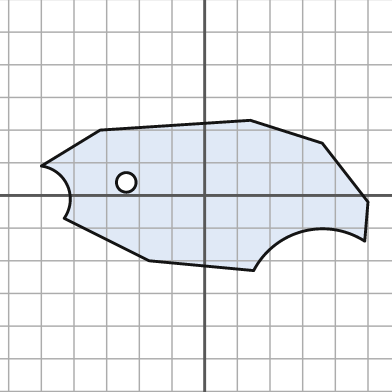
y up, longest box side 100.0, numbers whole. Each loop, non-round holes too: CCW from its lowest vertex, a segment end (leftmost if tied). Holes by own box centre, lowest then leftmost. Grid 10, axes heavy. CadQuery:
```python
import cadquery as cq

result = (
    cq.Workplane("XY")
    .moveTo(15.0, -23.0)
    .threePointArc((30.0, -11.0), (49.0, -14.0))
    .lineTo(50.0, -2.0)
    .lineTo(36.0, 16.0)
    .lineTo(14.0, 23.0)
    .lineTo(-32.0, 20.0)
    .lineTo(-50.0, 9.0)
    .threePointArc((-42.0, 3.0), (-43.0, -7.0))
    .lineTo(-17.0, -20.0)
    .close()
    .moveTo(-24.0, 4.0)
    .circle(3.0)
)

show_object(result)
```